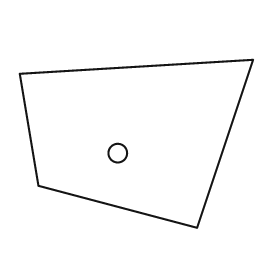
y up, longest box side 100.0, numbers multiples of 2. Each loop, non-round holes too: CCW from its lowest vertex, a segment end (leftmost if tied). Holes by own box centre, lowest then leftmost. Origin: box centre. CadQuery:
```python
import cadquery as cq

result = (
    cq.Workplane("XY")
    .moveTo(26.0, -36.0)
    .lineTo(50.0, 36.0)
    .lineTo(-50.0, 30.0)
    .lineTo(-42.0, -18.0)
    .close()
    .moveTo(-8.0, -4.0)
    .circle(4.0)
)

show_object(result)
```